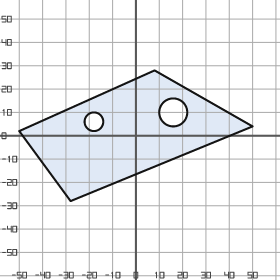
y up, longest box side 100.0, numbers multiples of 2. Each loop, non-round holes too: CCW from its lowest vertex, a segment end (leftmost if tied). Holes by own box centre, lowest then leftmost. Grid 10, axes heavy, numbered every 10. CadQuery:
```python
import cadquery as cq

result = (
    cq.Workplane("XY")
    .moveTo(-28.0, -28.0)
    .lineTo(50.0, 4.0)
    .lineTo(8.0, 28.0)
    .lineTo(-50.0, 2.0)
    .close()
    .moveTo(-18.0, 6.0)
    .circle(4.0)
    .moveTo(16.0, 10.0)
    .circle(6.0)
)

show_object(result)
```